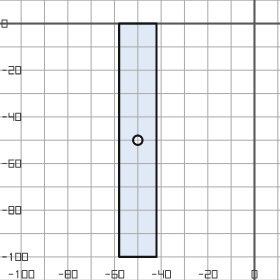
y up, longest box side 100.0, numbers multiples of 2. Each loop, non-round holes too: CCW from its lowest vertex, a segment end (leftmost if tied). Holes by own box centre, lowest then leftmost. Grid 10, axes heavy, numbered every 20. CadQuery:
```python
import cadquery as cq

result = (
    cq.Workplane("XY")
    .moveTo(-58.0, -100.0)
    .lineTo(-42.0, -100.0)
    .lineTo(-42.0, 0.0)
    .lineTo(-58.0, 0.0)
    .close()
    .moveTo(-50.0, -50.0)
    .circle(2.0)
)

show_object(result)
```